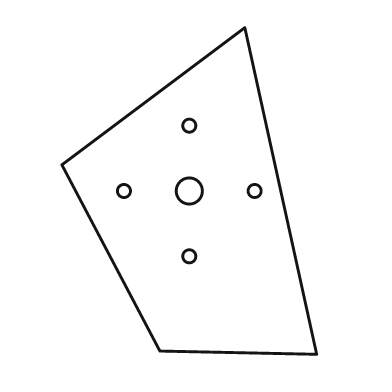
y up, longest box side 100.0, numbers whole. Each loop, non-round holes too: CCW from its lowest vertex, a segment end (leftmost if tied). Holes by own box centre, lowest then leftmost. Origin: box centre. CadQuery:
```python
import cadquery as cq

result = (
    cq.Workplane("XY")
    .moveTo(39.0, -50.0)
    .lineTo(17.0, 50.0)
    .lineTo(-39.0, 8.0)
    .lineTo(-9.0, -49.0)
    .close()
    .moveTo(0.0, -20.0)
    .circle(2.0)
    .moveTo(-20.0, 0.0)
    .circle(2.0)
    .moveTo(0.0, 0.0)
    .circle(4.0)
    .moveTo(20.0, 0.0)
    .circle(2.0)
    .moveTo(0.0, 20.0)
    .circle(2.0)
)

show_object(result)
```